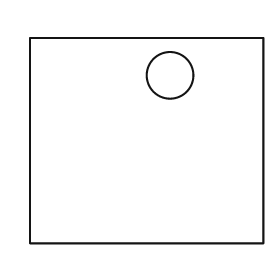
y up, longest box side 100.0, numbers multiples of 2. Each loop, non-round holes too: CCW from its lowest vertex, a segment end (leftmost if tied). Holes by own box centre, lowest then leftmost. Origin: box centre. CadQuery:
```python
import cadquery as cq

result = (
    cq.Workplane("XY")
    .moveTo(-50.0, -44.0)
    .lineTo(50.0, -44.0)
    .lineTo(50.0, 44.0)
    .lineTo(-50.0, 44.0)
    .close()
    .moveTo(10.0, 28.0)
    .circle(10.0)
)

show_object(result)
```